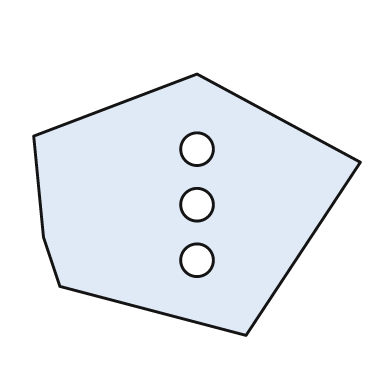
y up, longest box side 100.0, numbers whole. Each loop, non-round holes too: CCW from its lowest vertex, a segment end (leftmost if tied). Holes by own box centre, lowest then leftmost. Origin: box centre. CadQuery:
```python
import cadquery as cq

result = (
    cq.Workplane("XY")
    .moveTo(15.0, -40.0)
    .lineTo(50.0, 13.0)
    .lineTo(0.0, 40.0)
    .lineTo(-50.0, 21.0)
    .lineTo(-47.0, -10.0)
    .lineTo(-42.0, -25.0)
    .close()
    .moveTo(0.0, -17.0)
    .circle(5.0)
    .moveTo(0.0, 0.0)
    .circle(5.0)
    .moveTo(0.0, 17.0)
    .circle(5.0)
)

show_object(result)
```